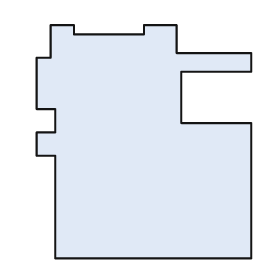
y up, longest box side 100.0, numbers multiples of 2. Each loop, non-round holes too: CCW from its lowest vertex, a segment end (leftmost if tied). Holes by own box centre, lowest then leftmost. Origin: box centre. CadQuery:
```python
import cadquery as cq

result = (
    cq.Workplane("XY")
    .moveTo(-38.0, -50.0)
    .lineTo(46.0, -50.0)
    .lineTo(46.0, 8.0)
    .lineTo(16.0, 8.0)
    .lineTo(16.0, 30.0)
    .lineTo(46.0, 30.0)
    .lineTo(46.0, 38.0)
    .lineTo(14.0, 38.0)
    .lineTo(14.0, 50.0)
    .lineTo(0.0, 50.0)
    .lineTo(0.0, 46.0)
    .lineTo(-30.0, 46.0)
    .lineTo(-30.0, 50.0)
    .lineTo(-40.0, 50.0)
    .lineTo(-40.0, 36.0)
    .lineTo(-46.0, 36.0)
    .lineTo(-46.0, 14.0)
    .lineTo(-38.0, 14.0)
    .lineTo(-38.0, 4.0)
    .lineTo(-46.0, 4.0)
    .lineTo(-46.0, -6.0)
    .lineTo(-38.0, -6.0)
    .close()
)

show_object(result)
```